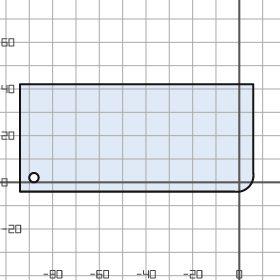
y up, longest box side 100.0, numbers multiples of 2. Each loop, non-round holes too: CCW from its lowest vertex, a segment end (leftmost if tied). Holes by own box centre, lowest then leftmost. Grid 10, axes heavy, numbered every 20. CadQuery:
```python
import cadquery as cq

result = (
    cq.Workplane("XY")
    .moveTo(-94.0, -4.0)
    .lineTo(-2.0, -4.0)
    .threePointArc((4.0, -2.0), (6.0, 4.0))
    .lineTo(6.0, 42.0)
    .lineTo(-94.0, 42.0)
    .close()
    .moveTo(-88.0, 2.0)
    .circle(2.0)
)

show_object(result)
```